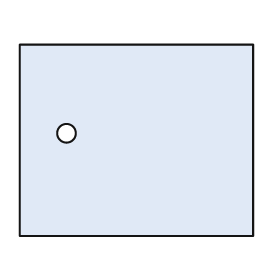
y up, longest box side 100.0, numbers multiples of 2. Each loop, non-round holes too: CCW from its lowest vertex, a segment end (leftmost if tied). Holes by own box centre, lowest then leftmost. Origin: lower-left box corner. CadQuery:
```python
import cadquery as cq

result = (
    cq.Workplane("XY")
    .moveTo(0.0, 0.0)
    .lineTo(100.0, 0.0)
    .lineTo(100.0, 82.0)
    .lineTo(0.0, 82.0)
    .close()
    .moveTo(20.0, 44.0)
    .circle(4.0)
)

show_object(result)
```